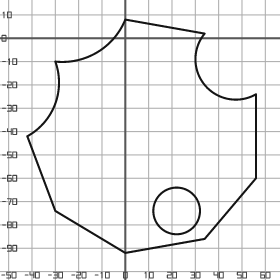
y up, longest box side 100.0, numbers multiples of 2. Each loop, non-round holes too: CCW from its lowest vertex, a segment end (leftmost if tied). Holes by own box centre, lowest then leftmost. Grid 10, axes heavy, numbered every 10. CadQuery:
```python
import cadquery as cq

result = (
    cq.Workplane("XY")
    .moveTo(0.0, -92.0)
    .lineTo(34.0, -86.0)
    .lineTo(56.0, -60.0)
    .lineTo(56.0, -24.0)
    .threePointArc((34.0, -20.0), (34.0, 2.0))
    .lineTo(0.0, 8.0)
    .threePointArc((-12.0, -6.0), (-30.0, -10.0))
    .threePointArc((-30.0, -28.0), (-42.0, -42.0))
    .lineTo(-30.0, -74.0)
    .close()
    .moveTo(22.0, -74.0)
    .circle(10.0)
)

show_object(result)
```